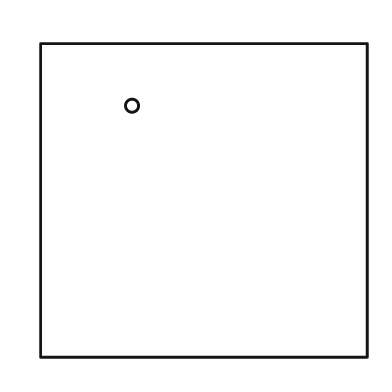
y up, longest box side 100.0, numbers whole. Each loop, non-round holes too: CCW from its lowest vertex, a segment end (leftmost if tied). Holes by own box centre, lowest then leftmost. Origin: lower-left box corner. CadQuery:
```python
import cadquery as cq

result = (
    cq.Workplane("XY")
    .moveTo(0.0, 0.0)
    .lineTo(100.0, 0.0)
    .lineTo(100.0, 96.0)
    .lineTo(0.0, 96.0)
    .close()
    .moveTo(28.0, 77.0)
    .circle(2.0)
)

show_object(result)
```